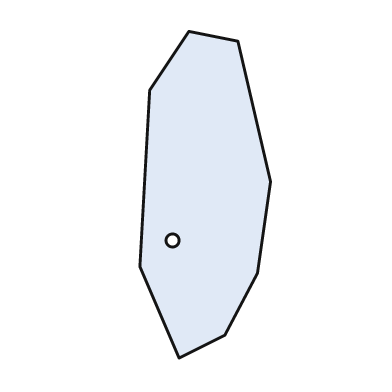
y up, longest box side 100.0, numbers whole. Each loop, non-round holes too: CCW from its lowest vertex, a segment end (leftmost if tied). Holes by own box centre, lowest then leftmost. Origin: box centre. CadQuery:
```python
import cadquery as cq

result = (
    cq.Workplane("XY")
    .moveTo(-8.0, -50.0)
    .lineTo(6.0, -43.0)
    .lineTo(16.0, -24.0)
    .lineTo(20.0, 4.0)
    .lineTo(10.0, 47.0)
    .lineTo(-5.0, 50.0)
    .lineTo(-17.0, 32.0)
    .lineTo(-20.0, -22.0)
    .close()
    .moveTo(-10.0, -14.0)
    .circle(2.0)
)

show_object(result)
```